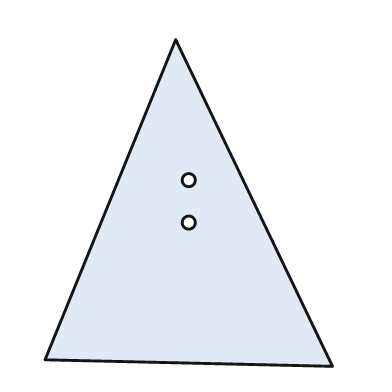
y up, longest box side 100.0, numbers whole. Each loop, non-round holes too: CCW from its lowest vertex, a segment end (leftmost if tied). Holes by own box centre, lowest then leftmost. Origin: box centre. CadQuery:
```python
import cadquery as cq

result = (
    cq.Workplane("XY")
    .moveTo(44.0, -50.0)
    .lineTo(-4.0, 50.0)
    .lineTo(-44.0, -48.0)
    .close()
    .moveTo(0.0, -6.0)
    .circle(2.0)
    .moveTo(0.0, 7.0)
    .circle(2.0)
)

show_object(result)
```